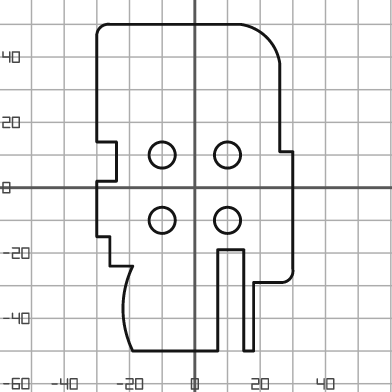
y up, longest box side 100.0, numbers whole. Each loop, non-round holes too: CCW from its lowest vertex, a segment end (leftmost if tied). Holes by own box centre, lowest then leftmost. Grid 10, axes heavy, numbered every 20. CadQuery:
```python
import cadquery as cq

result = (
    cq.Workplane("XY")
    .moveTo(-19.0, -50.0)
    .lineTo(7.0, -50.0)
    .lineTo(7.0, -19.0)
    .lineTo(15.0, -19.0)
    .lineTo(15.0, -50.0)
    .lineTo(18.0, -50.0)
    .lineTo(18.0, -29.0)
    .lineTo(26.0, -29.0)
    .threePointArc((29.0, -28.0), (30.0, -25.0))
    .lineTo(30.0, 11.0)
    .lineTo(26.0, 11.0)
    .lineTo(26.0, 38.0)
    .threePointArc((22.0, 46.0), (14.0, 50.0))
    .lineTo(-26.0, 50.0)
    .threePointArc((-29.0, 49.0), (-30.0, 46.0))
    .lineTo(-30.0, 14.0)
    .lineTo(-24.0, 14.0)
    .lineTo(-24.0, 2.0)
    .lineTo(-30.0, 2.0)
    .lineTo(-30.0, -15.0)
    .lineTo(-26.0, -15.0)
    .lineTo(-26.0, -24.0)
    .lineTo(-19.0, -24.0)
    .threePointArc((-22.0, -37.0), (-19.0, -50.0))
    .close()
    .moveTo(-10.0, -10.0)
    .circle(4.0)
    .moveTo(10.0, -10.0)
    .circle(4.0)
    .moveTo(-10.0, 10.0)
    .circle(4.0)
    .moveTo(10.0, 10.0)
    .circle(4.0)
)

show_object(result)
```